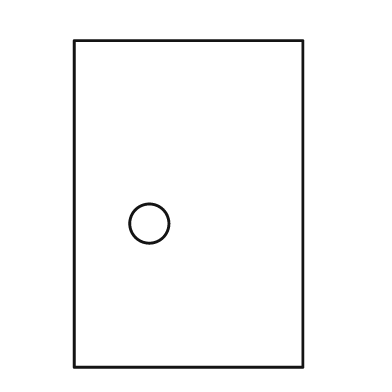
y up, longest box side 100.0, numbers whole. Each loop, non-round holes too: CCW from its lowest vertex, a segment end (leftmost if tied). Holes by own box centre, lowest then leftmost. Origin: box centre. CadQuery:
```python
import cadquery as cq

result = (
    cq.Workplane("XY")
    .moveTo(-35.0, -50.0)
    .lineTo(35.0, -50.0)
    .lineTo(35.0, 50.0)
    .lineTo(-35.0, 50.0)
    .close()
    .moveTo(-12.0, -6.0)
    .circle(6.0)
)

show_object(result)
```